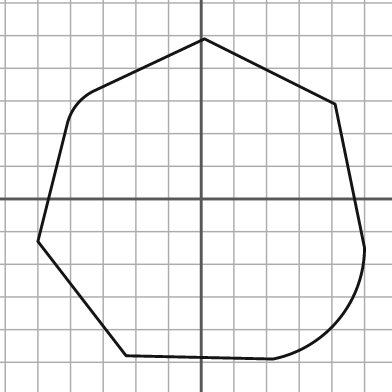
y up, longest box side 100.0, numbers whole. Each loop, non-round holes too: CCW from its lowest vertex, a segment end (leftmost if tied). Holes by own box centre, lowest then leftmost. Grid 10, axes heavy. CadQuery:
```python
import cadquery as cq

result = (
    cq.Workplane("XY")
    .moveTo(22.0, -49.0)
    .threePointArc((42.0, -37.0), (50.0, -15.0))
    .lineTo(41.0, 29.0)
    .lineTo(1.0, 49.0)
    .lineTo(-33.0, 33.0)
    .threePointArc((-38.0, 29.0), (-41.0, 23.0))
    .lineTo(-50.0, -13.0)
    .lineTo(-23.0, -48.0)
    .close()
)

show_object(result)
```